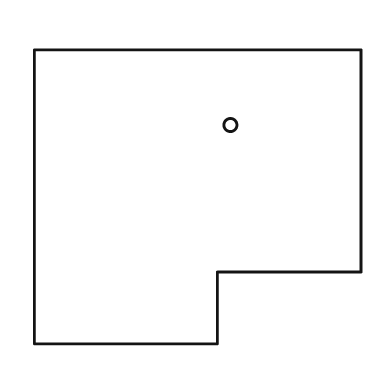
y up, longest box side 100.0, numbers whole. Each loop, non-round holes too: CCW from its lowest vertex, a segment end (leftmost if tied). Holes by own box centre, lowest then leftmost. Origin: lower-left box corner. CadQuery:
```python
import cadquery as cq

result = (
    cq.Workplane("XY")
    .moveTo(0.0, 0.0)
    .lineTo(56.0, 0.0)
    .lineTo(56.0, 22.0)
    .lineTo(100.0, 22.0)
    .lineTo(100.0, 90.0)
    .lineTo(0.0, 90.0)
    .close()
    .moveTo(60.0, 67.0)
    .circle(2.0)
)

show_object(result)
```